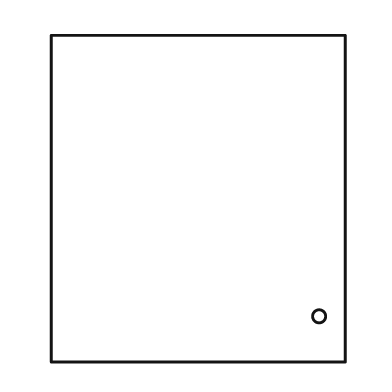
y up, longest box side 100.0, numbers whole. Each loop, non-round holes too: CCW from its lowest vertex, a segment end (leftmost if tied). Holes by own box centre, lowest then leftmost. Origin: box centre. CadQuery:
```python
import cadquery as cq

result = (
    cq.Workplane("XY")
    .moveTo(-45.0, -50.0)
    .lineTo(45.0, -50.0)
    .lineTo(45.0, 50.0)
    .lineTo(-45.0, 50.0)
    .close()
    .moveTo(37.0, -36.0)
    .circle(2.0)
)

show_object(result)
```